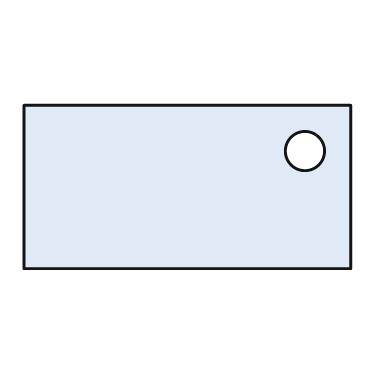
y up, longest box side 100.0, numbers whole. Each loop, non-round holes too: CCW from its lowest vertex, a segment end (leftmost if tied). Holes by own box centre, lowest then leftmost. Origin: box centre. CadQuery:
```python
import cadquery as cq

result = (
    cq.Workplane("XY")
    .moveTo(-50.0, -25.0)
    .lineTo(50.0, -25.0)
    .lineTo(50.0, 25.0)
    .lineTo(-50.0, 25.0)
    .close()
    .moveTo(36.0, 11.0)
    .circle(6.0)
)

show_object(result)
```